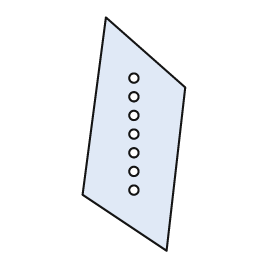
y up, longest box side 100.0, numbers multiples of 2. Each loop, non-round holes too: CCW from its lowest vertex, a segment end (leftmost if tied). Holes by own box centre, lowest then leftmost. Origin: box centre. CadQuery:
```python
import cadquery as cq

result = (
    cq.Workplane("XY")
    .moveTo(14.0, -50.0)
    .lineTo(22.0, 20.0)
    .lineTo(-12.0, 50.0)
    .lineTo(-22.0, -26.0)
    .close()
    .moveTo(0.0, -24.0)
    .circle(2.0)
    .moveTo(0.0, -16.0)
    .circle(2.0)
    .moveTo(0.0, -8.0)
    .circle(2.0)
    .moveTo(0.0, 0.0)
    .circle(2.0)
    .moveTo(0.0, 8.0)
    .circle(2.0)
    .moveTo(0.0, 16.0)
    .circle(2.0)
    .moveTo(0.0, 24.0)
    .circle(2.0)
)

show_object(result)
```